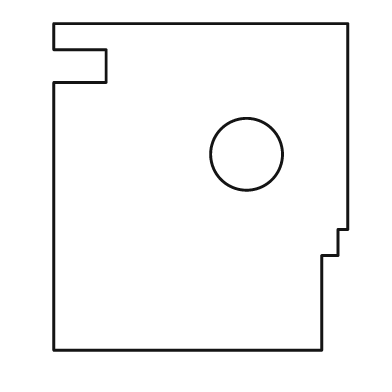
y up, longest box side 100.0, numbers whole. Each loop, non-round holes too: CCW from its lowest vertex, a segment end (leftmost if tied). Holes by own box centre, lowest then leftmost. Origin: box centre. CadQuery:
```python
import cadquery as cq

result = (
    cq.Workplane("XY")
    .moveTo(-45.0, -50.0)
    .lineTo(37.0, -50.0)
    .lineTo(37.0, -21.0)
    .lineTo(42.0, -21.0)
    .lineTo(42.0, -13.0)
    .lineTo(45.0, -13.0)
    .lineTo(45.0, 50.0)
    .lineTo(-45.0, 50.0)
    .lineTo(-45.0, 42.0)
    .lineTo(-29.0, 42.0)
    .lineTo(-29.0, 32.0)
    .lineTo(-45.0, 32.0)
    .close()
    .moveTo(14.0, 10.0)
    .circle(11.0)
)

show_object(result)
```